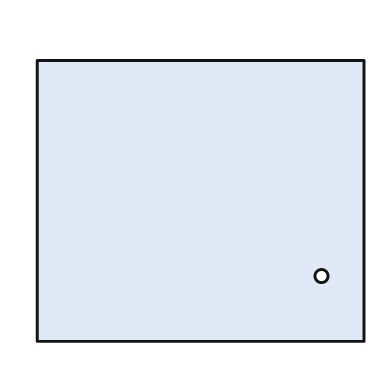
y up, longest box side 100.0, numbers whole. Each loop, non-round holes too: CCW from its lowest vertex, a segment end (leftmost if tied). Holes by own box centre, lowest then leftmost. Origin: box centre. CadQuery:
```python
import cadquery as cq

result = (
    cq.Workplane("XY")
    .moveTo(-50.0, -43.0)
    .lineTo(50.0, -43.0)
    .lineTo(50.0, 43.0)
    .lineTo(-50.0, 43.0)
    .close()
    .moveTo(37.0, -23.0)
    .circle(2.0)
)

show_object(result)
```